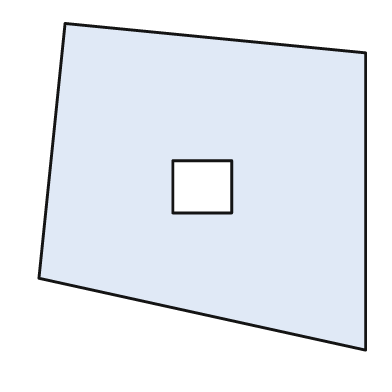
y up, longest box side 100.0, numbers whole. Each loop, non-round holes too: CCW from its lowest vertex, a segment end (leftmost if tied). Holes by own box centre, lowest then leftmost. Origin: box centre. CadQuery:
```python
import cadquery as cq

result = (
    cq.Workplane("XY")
    .moveTo(50.0, -50.0)
    .lineTo(50.0, 41.0)
    .lineTo(-42.0, 50.0)
    .lineTo(-50.0, -28.0)
    .close()
    .moveTo(-9.0, -8.0)
    .lineTo(9.0, -8.0)
    .lineTo(9.0, 8.0)
    .lineTo(-9.0, 8.0)
    .close()
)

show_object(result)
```